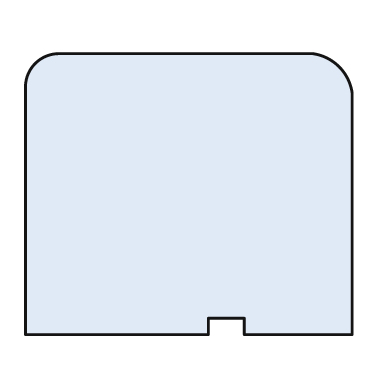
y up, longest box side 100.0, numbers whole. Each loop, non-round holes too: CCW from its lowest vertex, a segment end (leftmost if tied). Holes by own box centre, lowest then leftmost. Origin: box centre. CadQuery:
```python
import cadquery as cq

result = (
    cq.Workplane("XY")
    .moveTo(-50.0, -43.0)
    .lineTo(6.0, -43.0)
    .lineTo(6.0, -38.0)
    .lineTo(17.0, -38.0)
    .lineTo(17.0, -43.0)
    .lineTo(50.0, -43.0)
    .lineTo(50.0, 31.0)
    .threePointArc((46.0, 39.0), (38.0, 43.0))
    .lineTo(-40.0, 43.0)
    .threePointArc((-47.0, 40.0), (-50.0, 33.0))
    .close()
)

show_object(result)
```